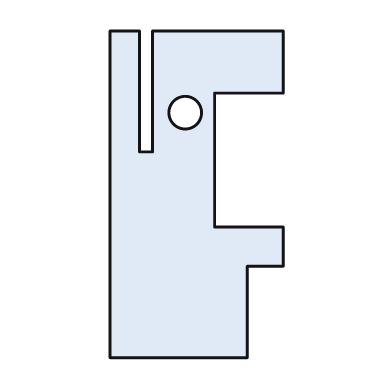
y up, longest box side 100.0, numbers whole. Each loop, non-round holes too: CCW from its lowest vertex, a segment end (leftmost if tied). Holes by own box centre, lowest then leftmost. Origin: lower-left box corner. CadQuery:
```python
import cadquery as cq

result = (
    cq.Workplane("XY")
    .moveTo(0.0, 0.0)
    .lineTo(42.0, 0.0)
    .lineTo(42.0, 28.0)
    .lineTo(53.0, 28.0)
    .lineTo(53.0, 40.0)
    .lineTo(32.0, 40.0)
    .lineTo(32.0, 81.0)
    .lineTo(53.0, 81.0)
    .lineTo(53.0, 100.0)
    .lineTo(13.0, 100.0)
    .lineTo(13.0, 63.0)
    .lineTo(9.0, 63.0)
    .lineTo(9.0, 100.0)
    .lineTo(0.0, 100.0)
    .close()
    .moveTo(23.0, 75.0)
    .circle(5.0)
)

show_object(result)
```